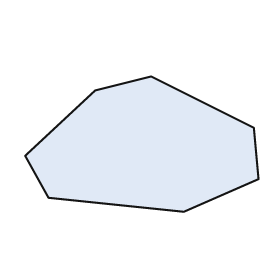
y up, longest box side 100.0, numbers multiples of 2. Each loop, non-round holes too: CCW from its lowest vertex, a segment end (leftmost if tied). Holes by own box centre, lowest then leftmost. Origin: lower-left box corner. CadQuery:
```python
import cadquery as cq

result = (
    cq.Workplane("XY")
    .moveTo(68.0, 0.0)
    .lineTo(100.0, 14.0)
    .lineTo(98.0, 36.0)
    .lineTo(54.0, 58.0)
    .lineTo(30.0, 52.0)
    .lineTo(0.0, 24.0)
    .lineTo(10.0, 6.0)
    .close()
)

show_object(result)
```